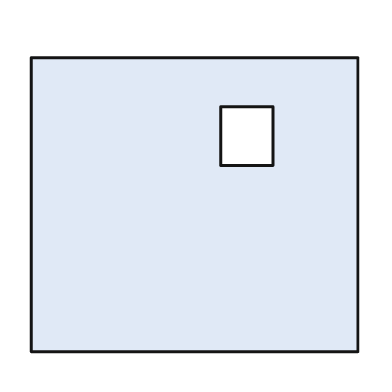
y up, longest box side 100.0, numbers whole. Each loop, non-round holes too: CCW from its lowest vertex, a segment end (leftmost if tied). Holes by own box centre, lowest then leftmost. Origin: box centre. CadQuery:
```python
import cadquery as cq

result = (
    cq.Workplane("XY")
    .moveTo(-50.0, -45.0)
    .lineTo(50.0, -45.0)
    .lineTo(50.0, 45.0)
    .lineTo(-50.0, 45.0)
    .close()
    .moveTo(8.0, 12.0)
    .lineTo(24.0, 12.0)
    .lineTo(24.0, 30.0)
    .lineTo(8.0, 30.0)
    .close()
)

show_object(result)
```